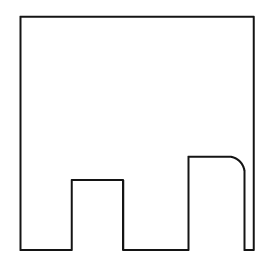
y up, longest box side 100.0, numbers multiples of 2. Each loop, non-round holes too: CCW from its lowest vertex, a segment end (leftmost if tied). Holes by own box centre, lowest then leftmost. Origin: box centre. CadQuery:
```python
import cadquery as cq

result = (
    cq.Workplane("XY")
    .moveTo(-50.0, -50.0)
    .lineTo(-28.0, -50.0)
    .lineTo(-28.0, -20.0)
    .lineTo(-6.0, -20.0)
    .lineTo(-6.0, -50.0)
    .lineTo(22.0, -50.0)
    .lineTo(22.0, -10.0)
    .lineTo(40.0, -10.0)
    .threePointArc((44.0, -12.0), (46.0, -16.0))
    .lineTo(46.0, -50.0)
    .lineTo(50.0, -50.0)
    .lineTo(50.0, 50.0)
    .lineTo(-50.0, 50.0)
    .close()
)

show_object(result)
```